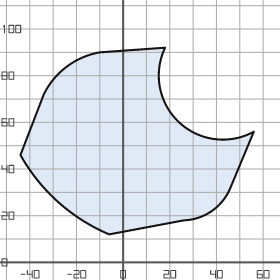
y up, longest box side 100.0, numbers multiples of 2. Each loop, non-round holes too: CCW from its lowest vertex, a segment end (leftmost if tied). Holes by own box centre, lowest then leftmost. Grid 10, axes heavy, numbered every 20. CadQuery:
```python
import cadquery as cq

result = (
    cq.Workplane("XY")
    .moveTo(-6.0, 12.0)
    .lineTo(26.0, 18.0)
    .threePointArc((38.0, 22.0), (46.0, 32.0))
    .lineTo(56.0, 56.0)
    .threePointArc((24.0, 60.0), (18.0, 92.0))
    .lineTo(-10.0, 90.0)
    .threePointArc((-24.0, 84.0), (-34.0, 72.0))
    .lineTo(-44.0, 46.0)
    .threePointArc((-28.0, 26.0), (-6.0, 12.0))
    .close()
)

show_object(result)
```